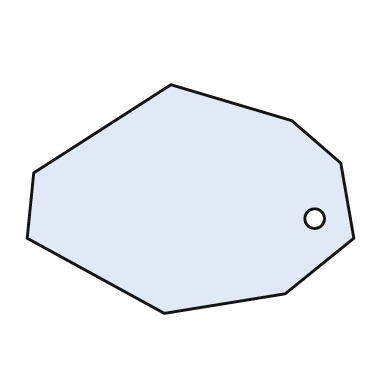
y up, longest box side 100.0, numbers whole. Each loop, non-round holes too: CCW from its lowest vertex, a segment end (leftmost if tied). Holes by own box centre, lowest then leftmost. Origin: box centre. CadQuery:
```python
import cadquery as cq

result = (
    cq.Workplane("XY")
    .moveTo(-8.0, -35.0)
    .lineTo(29.0, -29.0)
    .lineTo(50.0, -12.0)
    .lineTo(46.0, 11.0)
    .lineTo(31.0, 24.0)
    .lineTo(-6.0, 35.0)
    .lineTo(-48.0, 8.0)
    .lineTo(-50.0, -12.0)
    .close()
    .moveTo(38.0, -6.0)
    .circle(3.0)
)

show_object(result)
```